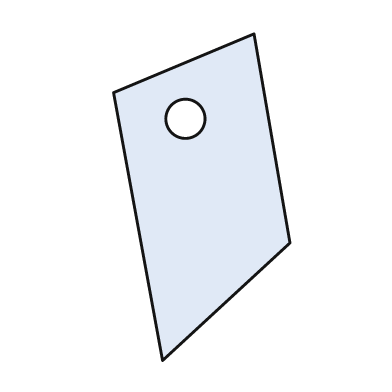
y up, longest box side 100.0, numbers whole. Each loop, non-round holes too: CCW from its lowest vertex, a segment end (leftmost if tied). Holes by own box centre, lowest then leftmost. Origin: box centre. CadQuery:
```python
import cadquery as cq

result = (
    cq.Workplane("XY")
    .moveTo(-12.0, -50.0)
    .lineTo(27.0, -14.0)
    .lineTo(16.0, 50.0)
    .lineTo(-27.0, 32.0)
    .close()
    .moveTo(-5.0, 24.0)
    .circle(6.0)
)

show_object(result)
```